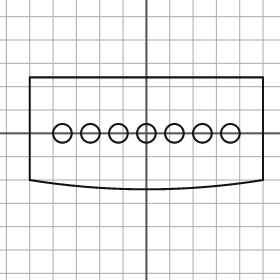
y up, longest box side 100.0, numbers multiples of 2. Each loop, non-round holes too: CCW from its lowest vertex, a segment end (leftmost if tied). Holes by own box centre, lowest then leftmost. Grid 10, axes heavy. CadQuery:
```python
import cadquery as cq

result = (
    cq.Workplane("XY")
    .moveTo(-50.0, -20.0)
    .threePointArc((0.0, -24.0), (50.0, -20.0))
    .lineTo(50.0, 24.0)
    .lineTo(-50.0, 24.0)
    .close()
    .moveTo(-36.0, 0.0)
    .circle(4.0)
    .moveTo(-24.0, 0.0)
    .circle(4.0)
    .moveTo(-12.0, 0.0)
    .circle(4.0)
    .moveTo(0.0, 0.0)
    .circle(4.0)
    .moveTo(12.0, 0.0)
    .circle(4.0)
    .moveTo(24.0, 0.0)
    .circle(4.0)
    .moveTo(36.0, 0.0)
    .circle(4.0)
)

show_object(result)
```